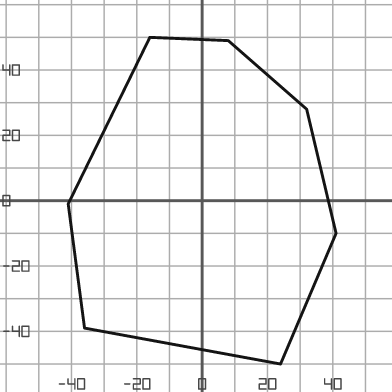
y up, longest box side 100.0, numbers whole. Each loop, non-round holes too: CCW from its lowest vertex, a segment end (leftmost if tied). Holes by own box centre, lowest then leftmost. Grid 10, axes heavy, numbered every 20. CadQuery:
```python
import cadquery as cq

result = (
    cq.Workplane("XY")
    .moveTo(24.0, -50.0)
    .lineTo(41.0, -10.0)
    .lineTo(32.0, 28.0)
    .lineTo(8.0, 49.0)
    .lineTo(-16.0, 50.0)
    .lineTo(-41.0, -1.0)
    .lineTo(-36.0, -39.0)
    .close()
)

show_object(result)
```